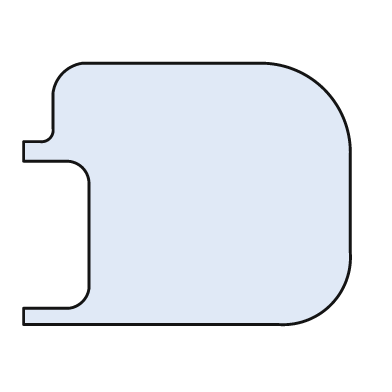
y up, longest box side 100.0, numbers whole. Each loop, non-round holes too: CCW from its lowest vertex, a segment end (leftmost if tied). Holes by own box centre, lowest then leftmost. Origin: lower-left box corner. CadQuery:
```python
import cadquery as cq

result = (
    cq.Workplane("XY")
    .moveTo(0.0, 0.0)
    .lineTo(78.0, 0.0)
    .threePointArc((94.0, 6.0), (100.0, 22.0))
    .lineTo(100.0, 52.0)
    .threePointArc((92.0, 72.0), (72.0, 80.0))
    .lineTo(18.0, 80.0)
    .threePointArc((12.0, 77.0), (9.0, 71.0))
    .lineTo(9.0, 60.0)
    .threePointArc((8.0, 57.0), (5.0, 56.0))
    .lineTo(0.0, 56.0)
    .lineTo(0.0, 50.0)
    .lineTo(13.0, 50.0)
    .threePointArc((18.0, 48.0), (20.0, 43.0))
    .lineTo(20.0, 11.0)
    .threePointArc((18.0, 7.0), (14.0, 5.0))
    .lineTo(0.0, 5.0)
    .close()
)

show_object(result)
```